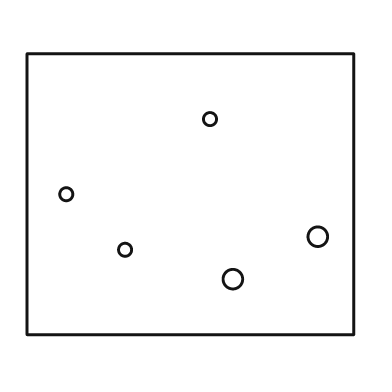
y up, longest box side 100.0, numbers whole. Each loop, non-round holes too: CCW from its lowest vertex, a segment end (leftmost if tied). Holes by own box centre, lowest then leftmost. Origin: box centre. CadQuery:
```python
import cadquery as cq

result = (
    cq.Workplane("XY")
    .moveTo(-50.0, -43.0)
    .lineTo(50.0, -43.0)
    .lineTo(50.0, 43.0)
    .lineTo(-50.0, 43.0)
    .close()
    .moveTo(13.0, -26.0)
    .circle(3.0)
    .moveTo(-20.0, -17.0)
    .circle(2.0)
    .moveTo(39.0, -13.0)
    .circle(3.0)
    .moveTo(-38.0, 0.0)
    .circle(2.0)
    .moveTo(6.0, 23.0)
    .circle(2.0)
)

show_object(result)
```